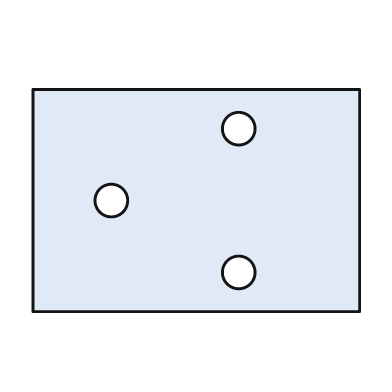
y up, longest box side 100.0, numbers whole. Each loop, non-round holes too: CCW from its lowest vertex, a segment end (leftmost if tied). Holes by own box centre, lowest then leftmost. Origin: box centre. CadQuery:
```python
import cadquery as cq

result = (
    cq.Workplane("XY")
    .moveTo(-50.0, -34.0)
    .lineTo(50.0, -34.0)
    .lineTo(50.0, 34.0)
    .lineTo(-50.0, 34.0)
    .close()
    .moveTo(13.0, -22.0)
    .circle(5.0)
    .moveTo(-26.0, 0.0)
    .circle(5.0)
    .moveTo(13.0, 22.0)
    .circle(5.0)
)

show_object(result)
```